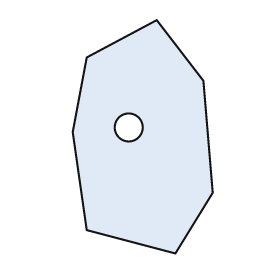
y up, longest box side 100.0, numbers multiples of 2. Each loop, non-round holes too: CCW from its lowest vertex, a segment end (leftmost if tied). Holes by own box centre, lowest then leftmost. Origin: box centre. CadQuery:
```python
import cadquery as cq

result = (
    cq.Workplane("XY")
    .moveTo(14.0, -50.0)
    .lineTo(30.0, -24.0)
    .lineTo(26.0, 24.0)
    .lineTo(6.0, 50.0)
    .lineTo(-24.0, 34.0)
    .lineTo(-30.0, 2.0)
    .lineTo(-24.0, -40.0)
    .close()
    .moveTo(-6.0, 4.0)
    .circle(6.0)
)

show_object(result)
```